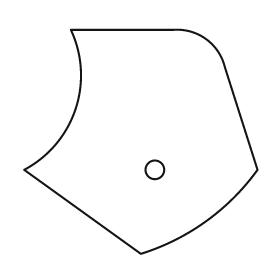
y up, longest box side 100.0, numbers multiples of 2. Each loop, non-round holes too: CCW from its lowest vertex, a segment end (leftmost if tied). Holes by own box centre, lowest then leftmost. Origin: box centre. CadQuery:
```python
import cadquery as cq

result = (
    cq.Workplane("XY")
    .moveTo(0.0, -48.0)
    .threePointArc((28.0, -34.0), (50.0, -12.0))
    .lineTo(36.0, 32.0)
    .threePointArc((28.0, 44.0), (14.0, 48.0))
    .lineTo(-30.0, 48.0)
    .threePointArc((-28.0, 14.0), (-50.0, -12.0))
    .close()
    .moveTo(6.0, -12.0)
    .circle(4.0)
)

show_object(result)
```